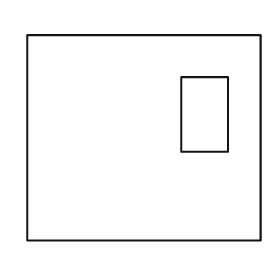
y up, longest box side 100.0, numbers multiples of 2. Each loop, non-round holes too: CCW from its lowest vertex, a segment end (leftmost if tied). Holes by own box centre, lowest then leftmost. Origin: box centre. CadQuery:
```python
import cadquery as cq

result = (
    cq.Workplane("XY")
    .moveTo(-50.0, -44.0)
    .lineTo(50.0, -44.0)
    .lineTo(50.0, 44.0)
    .lineTo(-50.0, 44.0)
    .close()
    .moveTo(16.0, -6.0)
    .lineTo(36.0, -6.0)
    .lineTo(36.0, 26.0)
    .lineTo(16.0, 26.0)
    .close()
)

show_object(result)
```